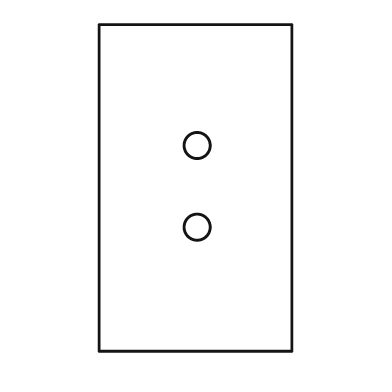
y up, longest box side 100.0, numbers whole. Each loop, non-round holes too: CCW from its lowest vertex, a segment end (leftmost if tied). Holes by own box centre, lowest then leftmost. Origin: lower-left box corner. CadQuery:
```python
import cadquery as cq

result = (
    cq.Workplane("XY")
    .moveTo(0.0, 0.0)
    .lineTo(59.0, 0.0)
    .lineTo(59.0, 100.0)
    .lineTo(0.0, 100.0)
    .close()
    .moveTo(30.0, 38.0)
    .circle(4.0)
    .moveTo(30.0, 63.0)
    .circle(4.0)
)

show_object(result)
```